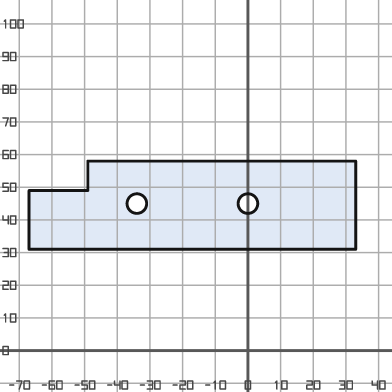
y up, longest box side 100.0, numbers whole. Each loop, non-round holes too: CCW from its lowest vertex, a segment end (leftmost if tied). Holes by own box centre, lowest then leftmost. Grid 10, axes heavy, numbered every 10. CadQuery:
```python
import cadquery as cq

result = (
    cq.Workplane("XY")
    .moveTo(-67.0, 31.0)
    .lineTo(33.0, 31.0)
    .lineTo(33.0, 58.0)
    .lineTo(-49.0, 58.0)
    .lineTo(-49.0, 49.0)
    .lineTo(-67.0, 49.0)
    .close()
    .moveTo(-34.0, 45.0)
    .circle(3.0)
    .moveTo(0.0, 45.0)
    .circle(3.0)
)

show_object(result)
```